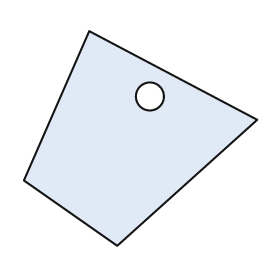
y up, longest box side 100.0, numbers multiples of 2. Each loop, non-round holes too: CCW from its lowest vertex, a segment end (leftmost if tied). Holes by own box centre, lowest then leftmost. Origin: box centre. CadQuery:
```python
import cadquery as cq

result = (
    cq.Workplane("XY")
    .moveTo(-10.0, -46.0)
    .lineTo(50.0, 8.0)
    .lineTo(-22.0, 46.0)
    .lineTo(-50.0, -18.0)
    .close()
    .moveTo(4.0, 18.0)
    .circle(6.0)
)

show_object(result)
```